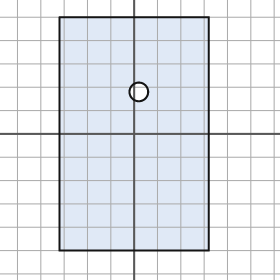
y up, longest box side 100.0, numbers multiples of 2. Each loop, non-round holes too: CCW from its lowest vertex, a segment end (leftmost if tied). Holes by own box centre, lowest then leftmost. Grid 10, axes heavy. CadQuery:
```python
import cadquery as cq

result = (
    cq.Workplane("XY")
    .moveTo(-32.0, -50.0)
    .lineTo(32.0, -50.0)
    .lineTo(32.0, 50.0)
    .lineTo(-32.0, 50.0)
    .close()
    .moveTo(2.0, 18.0)
    .circle(4.0)
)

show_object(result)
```